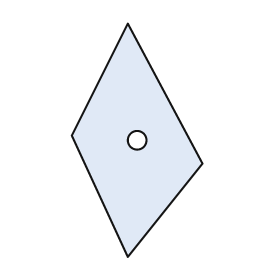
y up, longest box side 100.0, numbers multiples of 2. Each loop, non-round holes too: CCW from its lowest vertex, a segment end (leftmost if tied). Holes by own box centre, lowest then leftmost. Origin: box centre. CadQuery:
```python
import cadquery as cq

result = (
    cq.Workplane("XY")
    .moveTo(-4.0, -50.0)
    .lineTo(28.0, -10.0)
    .lineTo(-4.0, 50.0)
    .lineTo(-28.0, 2.0)
    .close()
    .moveTo(0.0, 0.0)
    .circle(4.0)
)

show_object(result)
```